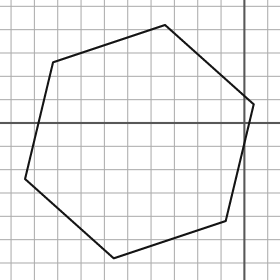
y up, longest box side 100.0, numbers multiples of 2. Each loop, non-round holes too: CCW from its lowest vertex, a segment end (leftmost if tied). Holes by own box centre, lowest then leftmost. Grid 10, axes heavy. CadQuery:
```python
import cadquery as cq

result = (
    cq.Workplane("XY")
    .moveTo(-56.0, -58.0)
    .lineTo(-8.0, -42.0)
    .lineTo(4.0, 8.0)
    .lineTo(-34.0, 42.0)
    .lineTo(-82.0, 26.0)
    .lineTo(-94.0, -24.0)
    .close()
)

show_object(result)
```